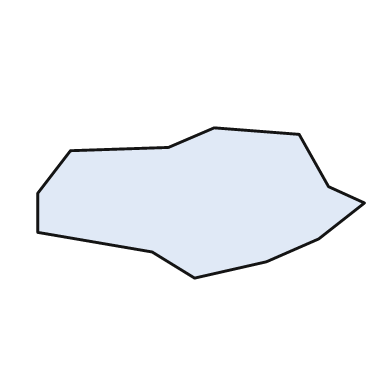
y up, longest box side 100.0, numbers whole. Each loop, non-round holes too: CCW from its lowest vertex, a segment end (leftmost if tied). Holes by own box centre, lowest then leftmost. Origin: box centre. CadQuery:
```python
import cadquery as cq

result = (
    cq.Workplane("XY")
    .moveTo(-2.0, -23.0)
    .lineTo(20.0, -18.0)
    .lineTo(36.0, -11.0)
    .lineTo(50.0, 0.0)
    .lineTo(39.0, 5.0)
    .lineTo(30.0, 21.0)
    .lineTo(4.0, 23.0)
    .lineTo(-10.0, 17.0)
    .lineTo(-40.0, 16.0)
    .lineTo(-50.0, 3.0)
    .lineTo(-50.0, -9.0)
    .lineTo(-15.0, -15.0)
    .close()
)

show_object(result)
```